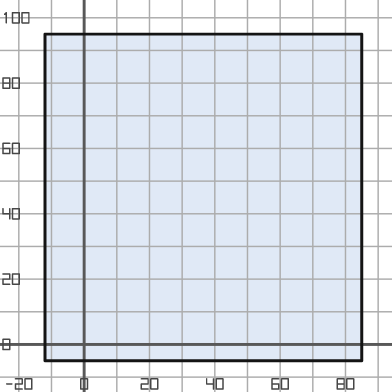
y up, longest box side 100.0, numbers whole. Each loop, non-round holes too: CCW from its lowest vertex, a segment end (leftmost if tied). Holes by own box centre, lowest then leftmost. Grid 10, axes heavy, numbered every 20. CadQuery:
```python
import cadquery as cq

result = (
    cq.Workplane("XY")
    .moveTo(-12.0, -5.0)
    .lineTo(85.0, -5.0)
    .lineTo(85.0, 95.0)
    .lineTo(-12.0, 95.0)
    .close()
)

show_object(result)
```